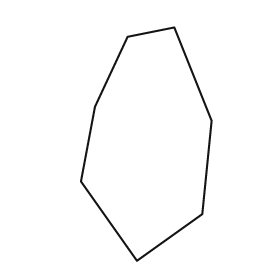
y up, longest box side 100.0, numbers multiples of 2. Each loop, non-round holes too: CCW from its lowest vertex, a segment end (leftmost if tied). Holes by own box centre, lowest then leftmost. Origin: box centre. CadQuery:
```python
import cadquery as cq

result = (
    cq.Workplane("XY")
    .moveTo(-4.0, -50.0)
    .lineTo(24.0, -30.0)
    .lineTo(28.0, 10.0)
    .lineTo(12.0, 50.0)
    .lineTo(-8.0, 46.0)
    .lineTo(-22.0, 16.0)
    .lineTo(-28.0, -16.0)
    .close()
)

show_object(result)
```